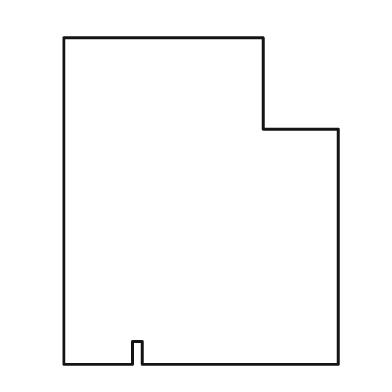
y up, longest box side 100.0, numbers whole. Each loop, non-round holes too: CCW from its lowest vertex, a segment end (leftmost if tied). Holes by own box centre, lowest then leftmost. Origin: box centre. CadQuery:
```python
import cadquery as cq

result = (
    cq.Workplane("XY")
    .moveTo(-42.0, -50.0)
    .lineTo(-21.0, -50.0)
    .lineTo(-21.0, -43.0)
    .lineTo(-18.0, -43.0)
    .lineTo(-18.0, -50.0)
    .lineTo(42.0, -50.0)
    .lineTo(42.0, 22.0)
    .lineTo(19.0, 22.0)
    .lineTo(19.0, 50.0)
    .lineTo(-42.0, 50.0)
    .close()
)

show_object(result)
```